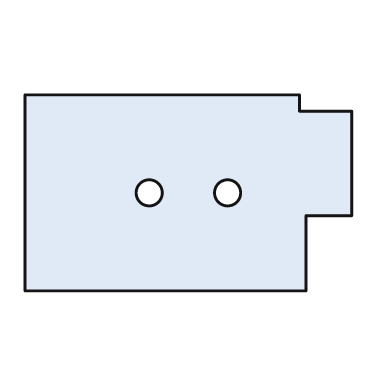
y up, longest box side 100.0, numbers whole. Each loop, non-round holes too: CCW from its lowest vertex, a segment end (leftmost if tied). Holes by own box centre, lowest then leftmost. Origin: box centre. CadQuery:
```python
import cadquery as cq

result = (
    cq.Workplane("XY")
    .moveTo(-50.0, -30.0)
    .lineTo(36.0, -30.0)
    .lineTo(36.0, -7.0)
    .lineTo(50.0, -7.0)
    .lineTo(50.0, 25.0)
    .lineTo(34.0, 25.0)
    .lineTo(34.0, 30.0)
    .lineTo(-50.0, 30.0)
    .close()
    .moveTo(-12.0, 0.0)
    .circle(4.0)
    .moveTo(12.0, 0.0)
    .circle(4.0)
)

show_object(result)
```